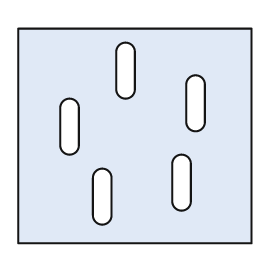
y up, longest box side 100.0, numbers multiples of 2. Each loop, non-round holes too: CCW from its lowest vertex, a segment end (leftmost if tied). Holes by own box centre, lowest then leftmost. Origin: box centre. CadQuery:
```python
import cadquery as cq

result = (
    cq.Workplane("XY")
    .moveTo(-50.0, -46.0)
    .lineTo(50.0, -46.0)
    .lineTo(50.0, 46.0)
    .lineTo(-50.0, 46.0)
    .close()
    .moveTo(-18.0, -34.0)
    .threePointArc((-14.0, -38.0), (-10.0, -34.0))
    .lineTo(-10.0, -18.0)
    .threePointArc((-14.0, -14.0), (-18.0, -18.0))
    .close()
    .moveTo(16.0, -28.0)
    .threePointArc((20.0, -32.0), (24.0, -28.0))
    .lineTo(24.0, -12.0)
    .threePointArc((20.0, -8.0), (16.0, -12.0))
    .close()
    .moveTo(-32.0, -4.0)
    .threePointArc((-28.0, -8.0), (-24.0, -4.0))
    .lineTo(-24.0, 12.0)
    .threePointArc((-28.0, 16.0), (-32.0, 12.0))
    .close()
    .moveTo(22.0, 6.0)
    .threePointArc((26.0, 2.0), (30.0, 6.0))
    .lineTo(30.0, 22.0)
    .threePointArc((26.0, 26.0), (22.0, 22.0))
    .close()
    .moveTo(-8.0, 20.0)
    .threePointArc((-4.0, 16.0), (0.0, 20.0))
    .lineTo(0.0, 36.0)
    .threePointArc((-4.0, 40.0), (-8.0, 36.0))
    .close()
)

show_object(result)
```